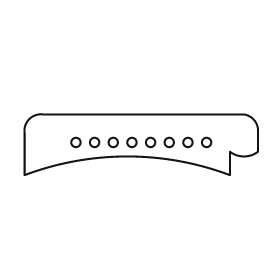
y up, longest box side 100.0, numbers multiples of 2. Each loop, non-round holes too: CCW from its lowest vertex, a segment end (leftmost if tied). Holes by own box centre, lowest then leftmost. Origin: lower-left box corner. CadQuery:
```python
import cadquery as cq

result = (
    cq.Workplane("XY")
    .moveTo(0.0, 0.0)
    .threePointArc((44.0, 8.0), (88.0, 0.0))
    .lineTo(88.0, 10.0)
    .threePointArc((94.0, 8.0), (100.0, 10.0))
    .lineTo(100.0, 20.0)
    .threePointArc((98.0, 24.0), (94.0, 26.0))
    .lineTo(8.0, 26.0)
    .threePointArc((2.0, 24.0), (0.0, 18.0))
    .close()
    .moveTo(22.0, 14.0)
    .circle(2.0)
    .moveTo(30.0, 14.0)
    .circle(2.0)
    .moveTo(38.0, 14.0)
    .circle(2.0)
    .moveTo(46.0, 14.0)
    .circle(2.0)
    .moveTo(54.0, 14.0)
    .circle(2.0)
    .moveTo(62.0, 14.0)
    .circle(2.0)
    .moveTo(70.0, 14.0)
    .circle(2.0)
    .moveTo(78.0, 14.0)
    .circle(2.0)
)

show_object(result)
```